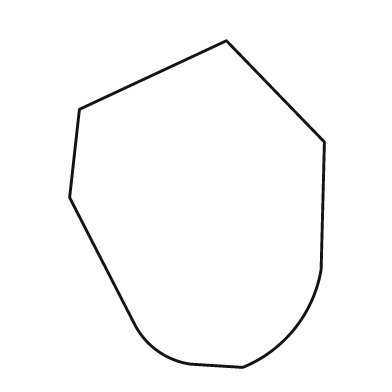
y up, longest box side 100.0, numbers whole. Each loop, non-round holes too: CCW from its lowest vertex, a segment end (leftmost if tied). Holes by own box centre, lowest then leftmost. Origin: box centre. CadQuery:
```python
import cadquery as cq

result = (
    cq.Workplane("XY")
    .moveTo(14.0, -50.0)
    .threePointArc((30.0, -38.0), (38.0, -20.0))
    .lineTo(39.0, 19.0)
    .lineTo(9.0, 50.0)
    .lineTo(-36.0, 29.0)
    .lineTo(-39.0, 2.0)
    .lineTo(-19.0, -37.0)
    .threePointArc((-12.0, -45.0), (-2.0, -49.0))
    .close()
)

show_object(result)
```